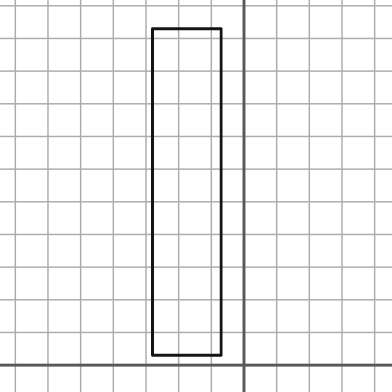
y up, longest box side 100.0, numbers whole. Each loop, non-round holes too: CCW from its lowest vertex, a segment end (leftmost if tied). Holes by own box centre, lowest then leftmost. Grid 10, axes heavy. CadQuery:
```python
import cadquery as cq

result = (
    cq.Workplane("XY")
    .moveTo(-28.0, 3.0)
    .lineTo(-7.0, 3.0)
    .lineTo(-7.0, 103.0)
    .lineTo(-28.0, 103.0)
    .close()
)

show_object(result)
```